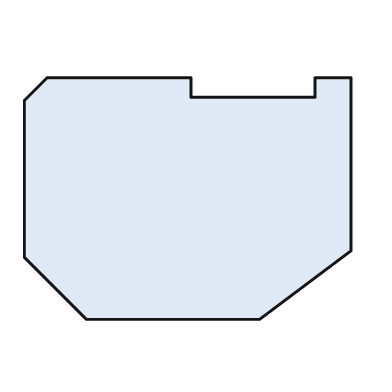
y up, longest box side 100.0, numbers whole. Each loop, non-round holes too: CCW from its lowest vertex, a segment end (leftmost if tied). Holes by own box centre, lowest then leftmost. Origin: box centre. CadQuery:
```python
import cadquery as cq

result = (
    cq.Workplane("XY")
    .moveTo(-31.0, -37.0)
    .lineTo(22.0, -37.0)
    .lineTo(50.0, -16.0)
    .lineTo(50.0, 37.0)
    .lineTo(39.0, 37.0)
    .lineTo(39.0, 31.0)
    .lineTo(1.0, 31.0)
    .lineTo(1.0, 37.0)
    .lineTo(-43.0, 37.0)
    .lineTo(-50.0, 30.0)
    .lineTo(-50.0, -18.0)
    .close()
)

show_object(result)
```